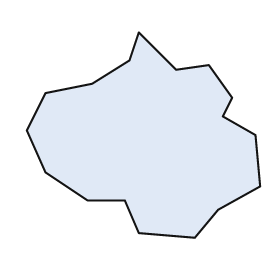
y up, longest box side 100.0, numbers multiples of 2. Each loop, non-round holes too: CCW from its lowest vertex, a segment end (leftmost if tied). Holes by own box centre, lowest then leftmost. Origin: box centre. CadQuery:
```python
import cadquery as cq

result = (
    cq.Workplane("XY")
    .moveTo(22.0, -44.0)
    .lineTo(32.0, -32.0)
    .lineTo(50.0, -22.0)
    .lineTo(48.0, 0.0)
    .lineTo(34.0, 8.0)
    .lineTo(38.0, 16.0)
    .lineTo(28.0, 30.0)
    .lineTo(14.0, 28.0)
    .lineTo(-2.0, 44.0)
    .lineTo(-6.0, 32.0)
    .lineTo(-22.0, 22.0)
    .lineTo(-42.0, 18.0)
    .lineTo(-50.0, 2.0)
    .lineTo(-42.0, -16.0)
    .lineTo(-24.0, -28.0)
    .lineTo(-8.0, -28.0)
    .lineTo(-2.0, -42.0)
    .close()
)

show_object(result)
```